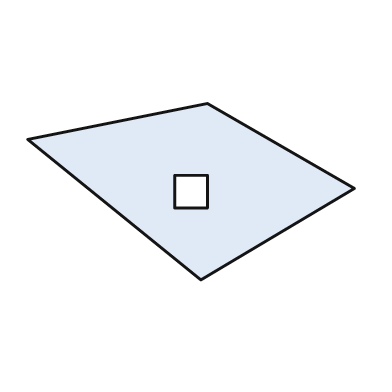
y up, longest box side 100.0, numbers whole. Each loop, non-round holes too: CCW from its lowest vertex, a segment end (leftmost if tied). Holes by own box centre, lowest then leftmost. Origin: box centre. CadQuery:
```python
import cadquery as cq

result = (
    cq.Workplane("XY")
    .moveTo(3.0, -27.0)
    .lineTo(50.0, 1.0)
    .lineTo(5.0, 27.0)
    .lineTo(-50.0, 16.0)
    .close()
    .moveTo(-5.0, -5.0)
    .lineTo(5.0, -5.0)
    .lineTo(5.0, 5.0)
    .lineTo(-5.0, 5.0)
    .close()
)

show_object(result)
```